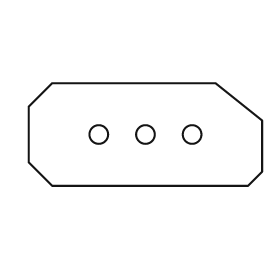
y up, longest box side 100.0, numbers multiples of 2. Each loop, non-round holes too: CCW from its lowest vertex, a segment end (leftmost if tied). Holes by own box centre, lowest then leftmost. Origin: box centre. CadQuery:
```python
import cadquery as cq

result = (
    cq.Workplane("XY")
    .moveTo(-40.0, -22.0)
    .lineTo(44.0, -22.0)
    .lineTo(50.0, -16.0)
    .lineTo(50.0, 6.0)
    .lineTo(30.0, 22.0)
    .lineTo(-40.0, 22.0)
    .lineTo(-50.0, 12.0)
    .lineTo(-50.0, -12.0)
    .close()
    .moveTo(-20.0, 0.0)
    .circle(4.0)
    .moveTo(0.0, 0.0)
    .circle(4.0)
    .moveTo(20.0, 0.0)
    .circle(4.0)
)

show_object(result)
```